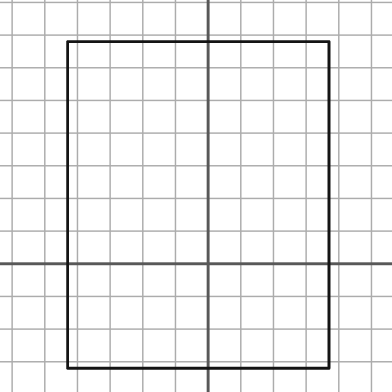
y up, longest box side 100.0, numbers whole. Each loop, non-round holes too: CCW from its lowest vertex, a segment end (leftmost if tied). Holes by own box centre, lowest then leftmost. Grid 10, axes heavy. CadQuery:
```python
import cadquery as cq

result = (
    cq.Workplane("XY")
    .moveTo(-43.0, -32.0)
    .lineTo(37.0, -32.0)
    .lineTo(37.0, 68.0)
    .lineTo(-43.0, 68.0)
    .close()
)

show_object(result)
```